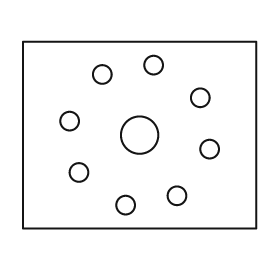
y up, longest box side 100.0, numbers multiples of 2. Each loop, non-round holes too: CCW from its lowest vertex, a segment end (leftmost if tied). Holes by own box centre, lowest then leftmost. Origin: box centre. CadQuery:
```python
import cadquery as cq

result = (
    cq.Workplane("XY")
    .moveTo(-50.0, -40.0)
    .lineTo(50.0, -40.0)
    .lineTo(50.0, 40.0)
    .lineTo(-50.0, 40.0)
    .close()
    .moveTo(-6.0, -30.0)
    .circle(4.0)
    .moveTo(16.0, -26.0)
    .circle(4.0)
    .moveTo(-26.0, -16.0)
    .circle(4.0)
    .moveTo(30.0, -6.0)
    .circle(4.0)
    .moveTo(0.0, 0.0)
    .circle(8.0)
    .moveTo(-30.0, 6.0)
    .circle(4.0)
    .moveTo(26.0, 16.0)
    .circle(4.0)
    .moveTo(-16.0, 26.0)
    .circle(4.0)
    .moveTo(6.0, 30.0)
    .circle(4.0)
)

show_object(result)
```